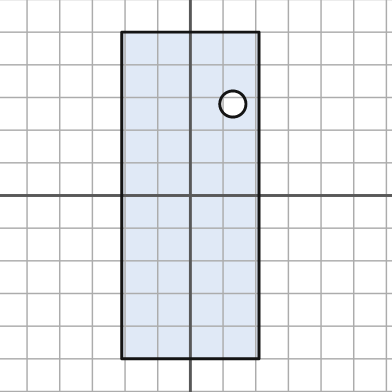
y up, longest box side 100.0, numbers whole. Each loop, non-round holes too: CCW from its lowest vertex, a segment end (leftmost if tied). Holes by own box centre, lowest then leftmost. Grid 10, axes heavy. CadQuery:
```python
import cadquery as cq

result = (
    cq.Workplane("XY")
    .moveTo(-21.0, -50.0)
    .lineTo(21.0, -50.0)
    .lineTo(21.0, 50.0)
    .lineTo(-21.0, 50.0)
    .close()
    .moveTo(13.0, 28.0)
    .circle(4.0)
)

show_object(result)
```